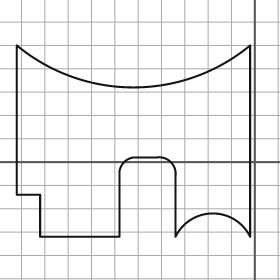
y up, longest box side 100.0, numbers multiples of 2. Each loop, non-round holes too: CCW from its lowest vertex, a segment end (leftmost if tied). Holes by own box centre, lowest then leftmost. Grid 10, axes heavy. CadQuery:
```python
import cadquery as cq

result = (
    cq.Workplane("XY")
    .moveTo(-92.0, -32.0)
    .lineTo(-58.0, -32.0)
    .lineTo(-58.0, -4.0)
    .threePointArc((-56.0, 0.0), (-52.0, 2.0))
    .lineTo(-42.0, 2.0)
    .threePointArc((-36.0, 0.0), (-34.0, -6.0))
    .lineTo(-34.0, -32.0)
    .threePointArc((-18.0, -22.0), (-2.0, -32.0))
    .lineTo(-2.0, 50.0)
    .threePointArc((-52.0, 32.0), (-102.0, 50.0))
    .lineTo(-102.0, -14.0)
    .lineTo(-92.0, -14.0)
    .close()
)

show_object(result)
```